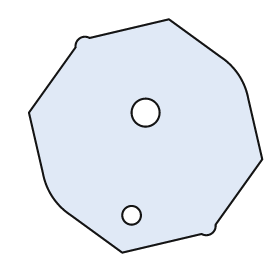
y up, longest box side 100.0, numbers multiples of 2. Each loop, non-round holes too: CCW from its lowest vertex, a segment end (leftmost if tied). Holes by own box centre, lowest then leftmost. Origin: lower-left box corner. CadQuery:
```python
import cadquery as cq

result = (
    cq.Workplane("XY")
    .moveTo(40.0, 0.0)
    .lineTo(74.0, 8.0)
    .threePointArc((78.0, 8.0), (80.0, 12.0))
    .lineTo(100.0, 40.0)
    .lineTo(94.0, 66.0)
    .threePointArc((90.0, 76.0), (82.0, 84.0))
    .lineTo(60.0, 100.0)
    .lineTo(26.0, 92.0)
    .threePointArc((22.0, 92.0), (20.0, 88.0))
    .lineTo(0.0, 60.0)
    .lineTo(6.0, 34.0)
    .threePointArc((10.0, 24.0), (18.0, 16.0))
    .close()
    .moveTo(44.0, 16.0)
    .circle(4.0)
    .moveTo(50.0, 60.0)
    .circle(6.0)
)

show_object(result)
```